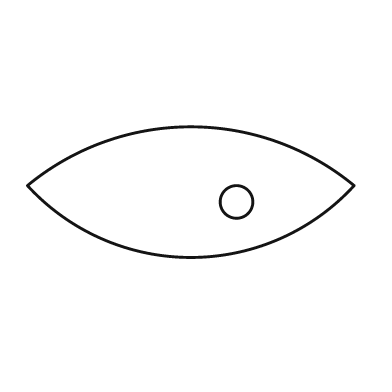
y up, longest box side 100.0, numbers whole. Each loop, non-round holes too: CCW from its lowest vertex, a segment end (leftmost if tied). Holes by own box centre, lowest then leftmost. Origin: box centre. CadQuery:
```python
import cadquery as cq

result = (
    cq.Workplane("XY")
    .moveTo(-50.0, 2.0)
    .threePointArc((0.0, -20.0), (50.0, 2.0))
    .threePointArc((0.0, 20.0), (-50.0, 2.0))
    .close()
    .moveTo(14.0, -3.0)
    .circle(5.0)
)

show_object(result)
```